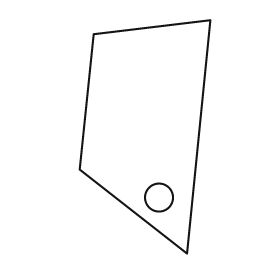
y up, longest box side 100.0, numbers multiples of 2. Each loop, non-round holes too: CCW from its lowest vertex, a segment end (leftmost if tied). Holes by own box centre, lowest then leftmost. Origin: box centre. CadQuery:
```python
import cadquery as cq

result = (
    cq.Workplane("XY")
    .moveTo(18.0, -50.0)
    .lineTo(28.0, 50.0)
    .lineTo(-22.0, 44.0)
    .lineTo(-28.0, -14.0)
    .close()
    .moveTo(6.0, -26.0)
    .circle(6.0)
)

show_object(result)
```